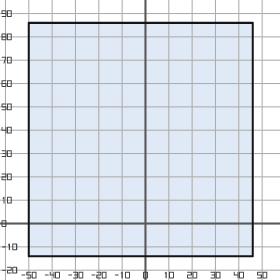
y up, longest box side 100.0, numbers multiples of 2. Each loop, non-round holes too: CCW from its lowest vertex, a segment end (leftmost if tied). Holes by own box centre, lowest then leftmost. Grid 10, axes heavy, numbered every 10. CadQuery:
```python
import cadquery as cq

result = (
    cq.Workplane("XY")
    .moveTo(-50.0, -14.0)
    .lineTo(46.0, -14.0)
    .lineTo(46.0, 86.0)
    .lineTo(-50.0, 86.0)
    .close()
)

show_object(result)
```